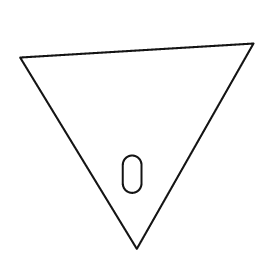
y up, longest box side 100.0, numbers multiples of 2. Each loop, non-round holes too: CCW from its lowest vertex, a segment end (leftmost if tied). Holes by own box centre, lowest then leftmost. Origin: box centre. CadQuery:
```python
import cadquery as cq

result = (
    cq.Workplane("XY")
    .moveTo(0.0, -44.0)
    .lineTo(50.0, 44.0)
    .lineTo(-50.0, 38.0)
    .close()
    .moveTo(-6.0, -16.0)
    .threePointArc((-2.0, -20.0), (2.0, -16.0))
    .lineTo(2.0, -8.0)
    .threePointArc((-2.0, -4.0), (-6.0, -8.0))
    .close()
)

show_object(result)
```